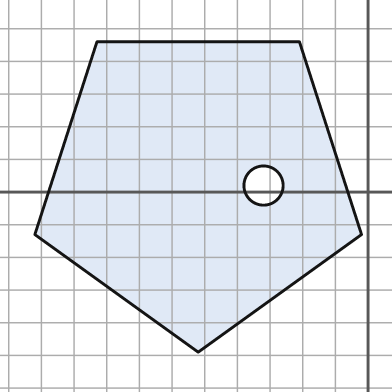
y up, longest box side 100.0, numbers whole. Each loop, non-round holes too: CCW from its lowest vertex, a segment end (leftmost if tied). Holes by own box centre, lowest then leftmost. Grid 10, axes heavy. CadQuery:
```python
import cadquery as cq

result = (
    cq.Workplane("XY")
    .moveTo(-52.0, -49.0)
    .lineTo(-2.0, -13.0)
    .lineTo(-21.0, 46.0)
    .lineTo(-83.0, 46.0)
    .lineTo(-102.0, -13.0)
    .close()
    .moveTo(-32.0, 2.0)
    .circle(6.0)
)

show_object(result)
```